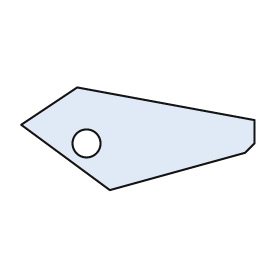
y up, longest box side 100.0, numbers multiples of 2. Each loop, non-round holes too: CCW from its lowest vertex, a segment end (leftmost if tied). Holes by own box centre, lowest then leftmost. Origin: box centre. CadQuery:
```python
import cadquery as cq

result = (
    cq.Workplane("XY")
    .moveTo(-12.0, -22.0)
    .lineTo(46.0, -6.0)
    .lineTo(50.0, -2.0)
    .lineTo(50.0, 8.0)
    .lineTo(-26.0, 22.0)
    .lineTo(-50.0, 6.0)
    .close()
    .moveTo(-22.0, -2.0)
    .circle(6.0)
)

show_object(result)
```